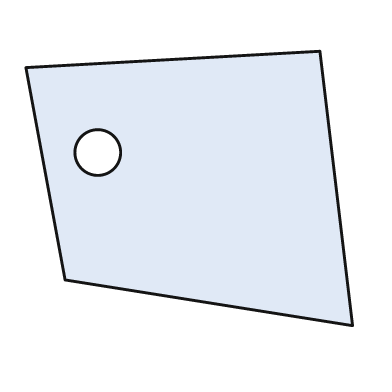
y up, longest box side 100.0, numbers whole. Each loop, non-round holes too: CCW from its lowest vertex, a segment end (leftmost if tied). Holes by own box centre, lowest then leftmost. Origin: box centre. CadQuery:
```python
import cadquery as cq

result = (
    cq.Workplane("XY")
    .moveTo(50.0, -42.0)
    .lineTo(40.0, 42.0)
    .lineTo(-50.0, 37.0)
    .lineTo(-38.0, -28.0)
    .close()
    .moveTo(-28.0, 11.0)
    .circle(7.0)
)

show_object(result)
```